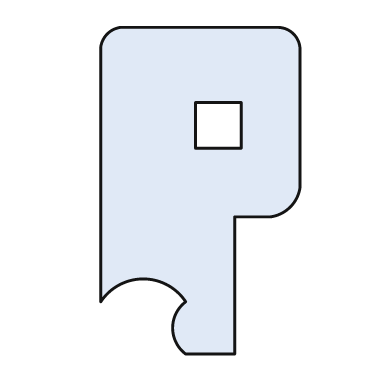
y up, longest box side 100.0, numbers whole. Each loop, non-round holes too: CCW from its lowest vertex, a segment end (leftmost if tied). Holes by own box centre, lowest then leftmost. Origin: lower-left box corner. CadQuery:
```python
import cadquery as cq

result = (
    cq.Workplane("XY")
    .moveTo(26.0, 0.0)
    .lineTo(41.0, 0.0)
    .lineTo(41.0, 42.0)
    .lineTo(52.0, 42.0)
    .threePointArc((58.0, 45.0), (61.0, 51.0))
    .lineTo(61.0, 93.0)
    .threePointArc((59.0, 98.0), (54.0, 100.0))
    .lineTo(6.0, 100.0)
    .threePointArc((2.0, 98.0), (0.0, 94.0))
    .lineTo(0.0, 16.0)
    .threePointArc((13.0, 23.0), (26.0, 16.0))
    .threePointArc((22.0, 8.0), (26.0, 0.0))
    .close()
    .moveTo(29.0, 63.0)
    .lineTo(43.0, 63.0)
    .lineTo(43.0, 77.0)
    .lineTo(29.0, 77.0)
    .close()
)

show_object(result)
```